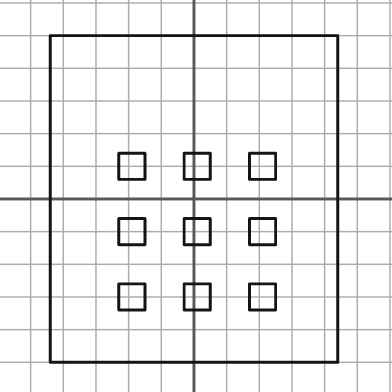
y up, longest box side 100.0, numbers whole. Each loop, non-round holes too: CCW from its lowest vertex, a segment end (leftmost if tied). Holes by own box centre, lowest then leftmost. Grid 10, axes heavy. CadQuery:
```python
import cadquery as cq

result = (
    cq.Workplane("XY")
    .moveTo(-44.0, -50.0)
    .lineTo(44.0, -50.0)
    .lineTo(44.0, 50.0)
    .lineTo(-44.0, 50.0)
    .close()
    .moveTo(-23.0, -34.0)
    .lineTo(-15.0, -34.0)
    .lineTo(-15.0, -26.0)
    .lineTo(-23.0, -26.0)
    .close()
    .moveTo(-3.0, -34.0)
    .lineTo(5.0, -34.0)
    .lineTo(5.0, -26.0)
    .lineTo(-3.0, -26.0)
    .close()
    .moveTo(17.0, -34.0)
    .lineTo(25.0, -34.0)
    .lineTo(25.0, -26.0)
    .lineTo(17.0, -26.0)
    .close()
    .moveTo(-23.0, -14.0)
    .lineTo(-15.0, -14.0)
    .lineTo(-15.0, -6.0)
    .lineTo(-23.0, -6.0)
    .close()
    .moveTo(-3.0, -14.0)
    .lineTo(5.0, -14.0)
    .lineTo(5.0, -6.0)
    .lineTo(-3.0, -6.0)
    .close()
    .moveTo(17.0, -14.0)
    .lineTo(25.0, -14.0)
    .lineTo(25.0, -6.0)
    .lineTo(17.0, -6.0)
    .close()
    .moveTo(-23.0, 6.0)
    .lineTo(-15.0, 6.0)
    .lineTo(-15.0, 14.0)
    .lineTo(-23.0, 14.0)
    .close()
    .moveTo(-3.0, 6.0)
    .lineTo(5.0, 6.0)
    .lineTo(5.0, 14.0)
    .lineTo(-3.0, 14.0)
    .close()
    .moveTo(17.0, 6.0)
    .lineTo(25.0, 6.0)
    .lineTo(25.0, 14.0)
    .lineTo(17.0, 14.0)
    .close()
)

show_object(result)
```